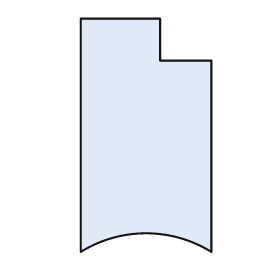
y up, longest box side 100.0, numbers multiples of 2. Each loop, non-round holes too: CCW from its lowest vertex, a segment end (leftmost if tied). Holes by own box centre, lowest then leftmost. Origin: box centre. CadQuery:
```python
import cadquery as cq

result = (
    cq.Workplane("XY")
    .moveTo(-28.0, -50.0)
    .threePointArc((0.0, -42.0), (28.0, -50.0))
    .lineTo(28.0, 32.0)
    .lineTo(6.0, 32.0)
    .lineTo(6.0, 50.0)
    .lineTo(-28.0, 50.0)
    .close()
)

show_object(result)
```